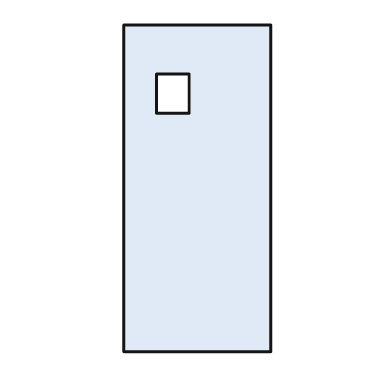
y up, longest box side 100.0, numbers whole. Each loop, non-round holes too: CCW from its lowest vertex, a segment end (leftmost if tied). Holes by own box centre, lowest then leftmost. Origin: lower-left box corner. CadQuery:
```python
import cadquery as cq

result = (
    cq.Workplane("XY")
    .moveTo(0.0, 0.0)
    .lineTo(45.0, 0.0)
    .lineTo(45.0, 100.0)
    .lineTo(0.0, 100.0)
    .close()
    .moveTo(10.0, 73.0)
    .lineTo(20.0, 73.0)
    .lineTo(20.0, 85.0)
    .lineTo(10.0, 85.0)
    .close()
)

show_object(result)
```